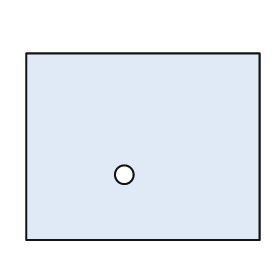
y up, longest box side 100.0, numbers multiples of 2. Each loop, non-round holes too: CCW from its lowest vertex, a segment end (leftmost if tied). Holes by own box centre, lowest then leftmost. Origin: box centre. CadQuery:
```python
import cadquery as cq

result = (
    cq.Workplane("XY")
    .moveTo(-50.0, -40.0)
    .lineTo(50.0, -40.0)
    .lineTo(50.0, 40.0)
    .lineTo(-50.0, 40.0)
    .close()
    .moveTo(-8.0, -12.0)
    .circle(4.0)
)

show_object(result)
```